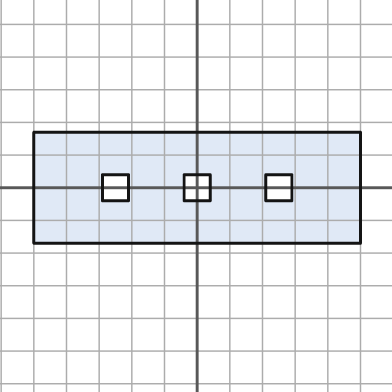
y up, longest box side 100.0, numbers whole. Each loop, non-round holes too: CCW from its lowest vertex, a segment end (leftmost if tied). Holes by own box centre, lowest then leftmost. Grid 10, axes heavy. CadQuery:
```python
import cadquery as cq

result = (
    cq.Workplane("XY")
    .moveTo(-50.0, -17.0)
    .lineTo(50.0, -17.0)
    .lineTo(50.0, 17.0)
    .lineTo(-50.0, 17.0)
    .close()
    .moveTo(-29.0, -4.0)
    .lineTo(-21.0, -4.0)
    .lineTo(-21.0, 4.0)
    .lineTo(-29.0, 4.0)
    .close()
    .moveTo(-4.0, -4.0)
    .lineTo(4.0, -4.0)
    .lineTo(4.0, 4.0)
    .lineTo(-4.0, 4.0)
    .close()
    .moveTo(21.0, -4.0)
    .lineTo(29.0, -4.0)
    .lineTo(29.0, 4.0)
    .lineTo(21.0, 4.0)
    .close()
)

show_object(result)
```